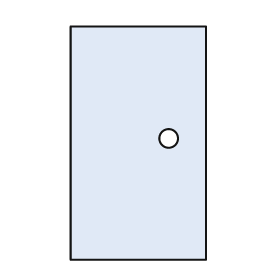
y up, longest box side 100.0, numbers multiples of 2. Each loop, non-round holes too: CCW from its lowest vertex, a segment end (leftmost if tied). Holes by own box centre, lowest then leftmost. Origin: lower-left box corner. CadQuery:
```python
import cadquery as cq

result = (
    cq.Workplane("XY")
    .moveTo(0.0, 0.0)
    .lineTo(58.0, 0.0)
    .lineTo(58.0, 100.0)
    .lineTo(0.0, 100.0)
    .close()
    .moveTo(42.0, 52.0)
    .circle(4.0)
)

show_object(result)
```